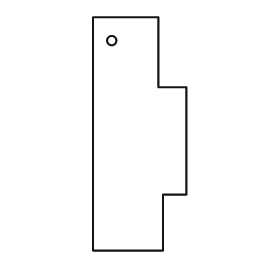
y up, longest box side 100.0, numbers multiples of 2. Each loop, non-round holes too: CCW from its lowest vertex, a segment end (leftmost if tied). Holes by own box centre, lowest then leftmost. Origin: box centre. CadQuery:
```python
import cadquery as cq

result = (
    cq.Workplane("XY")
    .moveTo(-20.0, -50.0)
    .lineTo(10.0, -50.0)
    .lineTo(10.0, -26.0)
    .lineTo(20.0, -26.0)
    .lineTo(20.0, 20.0)
    .lineTo(8.0, 20.0)
    .lineTo(8.0, 50.0)
    .lineTo(-20.0, 50.0)
    .close()
    .moveTo(-12.0, 40.0)
    .circle(2.0)
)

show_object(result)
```